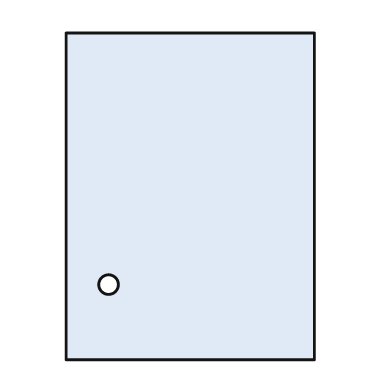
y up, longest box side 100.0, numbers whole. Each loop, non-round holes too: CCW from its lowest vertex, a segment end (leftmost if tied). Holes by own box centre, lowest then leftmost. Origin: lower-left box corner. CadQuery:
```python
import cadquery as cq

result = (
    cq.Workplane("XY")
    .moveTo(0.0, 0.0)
    .lineTo(76.0, 0.0)
    .lineTo(76.0, 100.0)
    .lineTo(0.0, 100.0)
    .close()
    .moveTo(13.0, 23.0)
    .circle(3.0)
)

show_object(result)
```